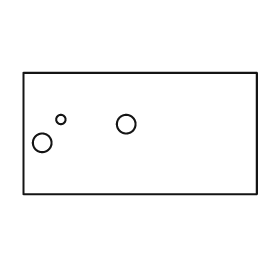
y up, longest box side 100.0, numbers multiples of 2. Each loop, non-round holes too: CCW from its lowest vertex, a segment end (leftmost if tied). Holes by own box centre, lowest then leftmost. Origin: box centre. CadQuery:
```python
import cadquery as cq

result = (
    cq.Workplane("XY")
    .moveTo(-50.0, -26.0)
    .lineTo(50.0, -26.0)
    .lineTo(50.0, 26.0)
    .lineTo(-50.0, 26.0)
    .close()
    .moveTo(-42.0, -4.0)
    .circle(4.0)
    .moveTo(-6.0, 4.0)
    .circle(4.0)
    .moveTo(-34.0, 6.0)
    .circle(2.0)
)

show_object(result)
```